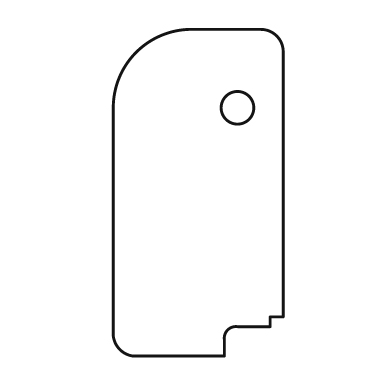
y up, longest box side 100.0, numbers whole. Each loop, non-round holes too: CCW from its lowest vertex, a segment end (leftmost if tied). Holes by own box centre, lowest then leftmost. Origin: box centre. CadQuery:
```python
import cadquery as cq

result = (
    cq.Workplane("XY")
    .moveTo(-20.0, -50.0)
    .lineTo(8.0, -50.0)
    .lineTo(8.0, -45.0)
    .threePointArc((9.0, -42.0), (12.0, -41.0))
    .lineTo(22.0, -41.0)
    .lineTo(22.0, -38.0)
    .lineTo(26.0, -38.0)
    .lineTo(26.0, 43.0)
    .threePointArc((24.0, 48.0), (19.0, 50.0))
    .lineTo(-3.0, 50.0)
    .threePointArc((-19.0, 43.0), (-26.0, 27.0))
    .lineTo(-26.0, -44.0)
    .threePointArc((-24.0, -48.0), (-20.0, -50.0))
    .close()
    .moveTo(12.0, 26.0)
    .circle(5.0)
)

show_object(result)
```